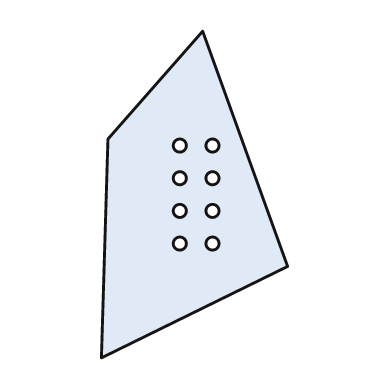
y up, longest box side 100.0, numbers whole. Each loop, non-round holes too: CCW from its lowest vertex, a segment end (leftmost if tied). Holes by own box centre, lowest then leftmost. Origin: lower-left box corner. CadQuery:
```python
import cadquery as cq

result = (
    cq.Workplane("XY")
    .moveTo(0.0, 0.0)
    .lineTo(57.0, 28.0)
    .lineTo(31.0, 100.0)
    .lineTo(2.0, 67.0)
    .close()
    .moveTo(24.0, 35.0)
    .circle(2.0)
    .moveTo(34.0, 35.0)
    .circle(2.0)
    .moveTo(24.0, 45.0)
    .circle(2.0)
    .moveTo(34.0, 45.0)
    .circle(2.0)
    .moveTo(24.0, 55.0)
    .circle(2.0)
    .moveTo(34.0, 55.0)
    .circle(2.0)
    .moveTo(24.0, 65.0)
    .circle(2.0)
    .moveTo(34.0, 65.0)
    .circle(2.0)
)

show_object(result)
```